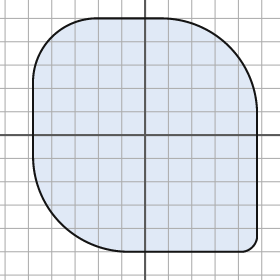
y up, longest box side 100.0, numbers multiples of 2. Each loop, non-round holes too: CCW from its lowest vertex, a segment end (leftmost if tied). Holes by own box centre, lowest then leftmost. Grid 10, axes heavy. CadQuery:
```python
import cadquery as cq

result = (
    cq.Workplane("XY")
    .moveTo(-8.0, -50.0)
    .lineTo(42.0, -50.0)
    .threePointArc((46.0, -48.0), (48.0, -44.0))
    .lineTo(48.0, 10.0)
    .threePointArc((36.0, 38.0), (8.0, 50.0))
    .lineTo(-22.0, 50.0)
    .threePointArc((-40.0, 42.0), (-48.0, 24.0))
    .lineTo(-48.0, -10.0)
    .threePointArc((-36.0, -38.0), (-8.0, -50.0))
    .close()
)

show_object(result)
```